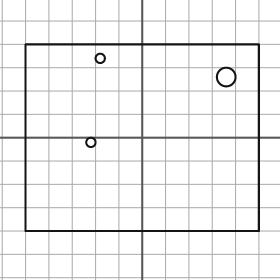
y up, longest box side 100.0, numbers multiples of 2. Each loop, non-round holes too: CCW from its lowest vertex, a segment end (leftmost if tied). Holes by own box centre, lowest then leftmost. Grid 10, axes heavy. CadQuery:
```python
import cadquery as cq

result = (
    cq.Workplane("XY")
    .moveTo(-50.0, -40.0)
    .lineTo(50.0, -40.0)
    .lineTo(50.0, 40.0)
    .lineTo(-50.0, 40.0)
    .close()
    .moveTo(-22.0, -2.0)
    .circle(2.0)
    .moveTo(36.0, 26.0)
    .circle(4.0)
    .moveTo(-18.0, 34.0)
    .circle(2.0)
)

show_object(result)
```